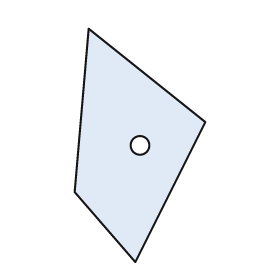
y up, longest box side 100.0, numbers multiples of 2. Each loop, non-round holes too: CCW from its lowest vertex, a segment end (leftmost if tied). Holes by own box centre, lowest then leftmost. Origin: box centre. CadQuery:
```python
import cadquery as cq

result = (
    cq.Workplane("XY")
    .moveTo(-2.0, -50.0)
    .lineTo(28.0, 10.0)
    .lineTo(-22.0, 50.0)
    .lineTo(-28.0, -20.0)
    .close()
    .moveTo(0.0, 0.0)
    .circle(4.0)
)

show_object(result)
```